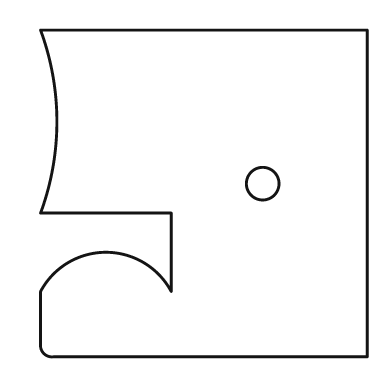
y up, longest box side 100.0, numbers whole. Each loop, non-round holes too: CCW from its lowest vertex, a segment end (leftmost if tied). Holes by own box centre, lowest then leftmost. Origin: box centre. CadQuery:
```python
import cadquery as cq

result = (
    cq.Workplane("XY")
    .moveTo(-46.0, -50.0)
    .lineTo(50.0, -50.0)
    .lineTo(50.0, 50.0)
    .lineTo(-50.0, 50.0)
    .threePointArc((-45.0, 22.0), (-50.0, -6.0))
    .lineTo(-10.0, -6.0)
    .lineTo(-10.0, -30.0)
    .threePointArc((-30.0, -18.0), (-50.0, -30.0))
    .lineTo(-50.0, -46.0)
    .threePointArc((-49.0, -49.0), (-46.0, -50.0))
    .close()
    .moveTo(18.0, 3.0)
    .circle(5.0)
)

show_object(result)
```